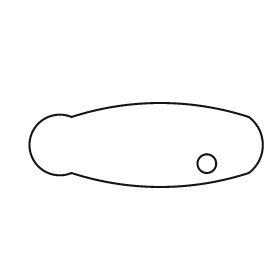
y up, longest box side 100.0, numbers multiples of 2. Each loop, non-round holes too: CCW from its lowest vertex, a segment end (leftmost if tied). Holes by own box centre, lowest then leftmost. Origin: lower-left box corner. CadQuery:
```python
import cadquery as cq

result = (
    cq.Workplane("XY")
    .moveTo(18.0, 6.0)
    .threePointArc((56.0, 0.0), (94.0, 6.0))
    .threePointArc((100.0, 18.0), (94.0, 30.0))
    .threePointArc((56.0, 36.0), (18.0, 30.0))
    .threePointArc((0.0, 18.0), (18.0, 6.0))
    .close()
    .moveTo(76.0, 10.0)
    .circle(4.0)
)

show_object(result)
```